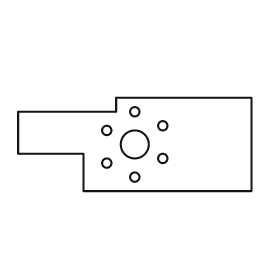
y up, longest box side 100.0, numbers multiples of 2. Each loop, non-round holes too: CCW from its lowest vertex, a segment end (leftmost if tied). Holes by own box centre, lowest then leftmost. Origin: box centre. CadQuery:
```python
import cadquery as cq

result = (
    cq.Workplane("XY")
    .moveTo(-22.0, -20.0)
    .lineTo(50.0, -20.0)
    .lineTo(50.0, 20.0)
    .lineTo(-8.0, 20.0)
    .lineTo(-8.0, 14.0)
    .lineTo(-50.0, 14.0)
    .lineTo(-50.0, -4.0)
    .lineTo(-22.0, -4.0)
    .close()
    .moveTo(0.0, -14.0)
    .circle(2.0)
    .moveTo(-12.0, -8.0)
    .circle(2.0)
    .moveTo(12.0, -6.0)
    .circle(2.0)
    .moveTo(0.0, 0.0)
    .circle(6.0)
    .moveTo(-12.0, 6.0)
    .circle(2.0)
    .moveTo(12.0, 8.0)
    .circle(2.0)
    .moveTo(0.0, 14.0)
    .circle(2.0)
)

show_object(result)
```